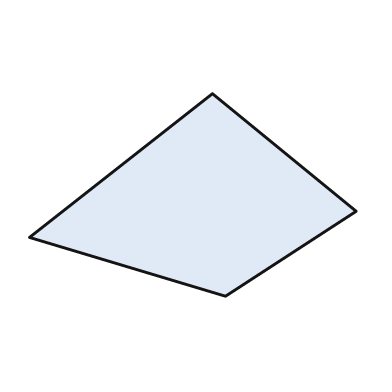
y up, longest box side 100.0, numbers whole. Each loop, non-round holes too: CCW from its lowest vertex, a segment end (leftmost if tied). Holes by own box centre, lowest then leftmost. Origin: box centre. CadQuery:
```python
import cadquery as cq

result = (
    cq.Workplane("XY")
    .moveTo(10.0, -31.0)
    .lineTo(50.0, -5.0)
    .lineTo(6.0, 31.0)
    .lineTo(-50.0, -13.0)
    .close()
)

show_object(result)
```